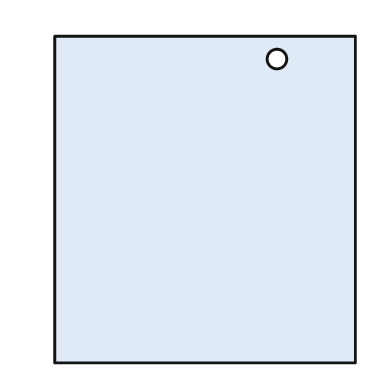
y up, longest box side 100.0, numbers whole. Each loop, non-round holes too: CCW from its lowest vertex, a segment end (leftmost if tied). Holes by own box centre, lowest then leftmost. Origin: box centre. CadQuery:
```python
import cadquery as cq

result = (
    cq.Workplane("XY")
    .moveTo(-46.0, -50.0)
    .lineTo(46.0, -50.0)
    .lineTo(46.0, 50.0)
    .lineTo(-46.0, 50.0)
    .close()
    .moveTo(22.0, 43.0)
    .circle(3.0)
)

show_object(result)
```